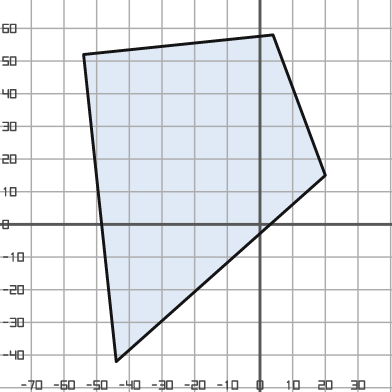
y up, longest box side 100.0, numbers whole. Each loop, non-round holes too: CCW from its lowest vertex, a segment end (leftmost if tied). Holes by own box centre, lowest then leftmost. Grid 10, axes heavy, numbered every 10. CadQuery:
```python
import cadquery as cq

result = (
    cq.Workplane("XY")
    .moveTo(-44.0, -42.0)
    .lineTo(20.0, 15.0)
    .lineTo(4.0, 58.0)
    .lineTo(-54.0, 52.0)
    .close()
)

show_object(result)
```